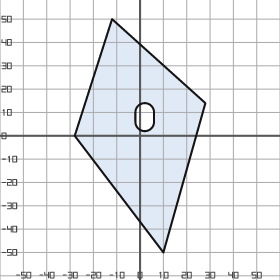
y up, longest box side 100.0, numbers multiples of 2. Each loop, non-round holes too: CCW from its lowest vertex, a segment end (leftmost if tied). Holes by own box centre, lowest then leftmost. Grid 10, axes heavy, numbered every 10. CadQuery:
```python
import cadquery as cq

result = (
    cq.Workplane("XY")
    .moveTo(10.0, -50.0)
    .lineTo(28.0, 14.0)
    .lineTo(-12.0, 50.0)
    .lineTo(-28.0, 0.0)
    .close()
    .moveTo(-2.0, 6.0)
    .threePointArc((2.0, 2.0), (6.0, 6.0))
    .lineTo(6.0, 10.0)
    .threePointArc((2.0, 14.0), (-2.0, 10.0))
    .close()
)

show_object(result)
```